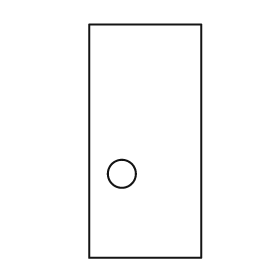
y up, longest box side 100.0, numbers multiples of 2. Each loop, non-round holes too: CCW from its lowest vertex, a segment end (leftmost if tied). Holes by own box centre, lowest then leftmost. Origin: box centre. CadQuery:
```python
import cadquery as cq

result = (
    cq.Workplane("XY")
    .moveTo(-24.0, -50.0)
    .lineTo(24.0, -50.0)
    .lineTo(24.0, 50.0)
    .lineTo(-24.0, 50.0)
    .close()
    .moveTo(-10.0, -14.0)
    .circle(6.0)
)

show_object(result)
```